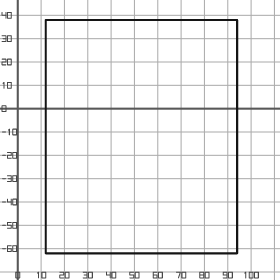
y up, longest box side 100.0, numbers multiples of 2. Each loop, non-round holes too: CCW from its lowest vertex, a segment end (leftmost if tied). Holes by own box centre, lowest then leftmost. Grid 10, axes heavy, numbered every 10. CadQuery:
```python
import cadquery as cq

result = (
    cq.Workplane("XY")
    .moveTo(12.0, -62.0)
    .lineTo(94.0, -62.0)
    .lineTo(94.0, 38.0)
    .lineTo(12.0, 38.0)
    .close()
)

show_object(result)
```